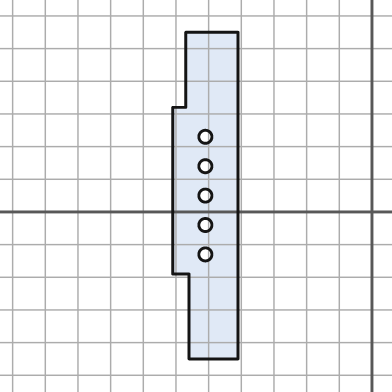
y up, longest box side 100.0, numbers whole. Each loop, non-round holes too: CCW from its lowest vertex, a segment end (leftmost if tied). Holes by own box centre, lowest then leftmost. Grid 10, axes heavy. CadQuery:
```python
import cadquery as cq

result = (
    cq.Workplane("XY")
    .moveTo(-56.0, -45.0)
    .lineTo(-41.0, -45.0)
    .lineTo(-41.0, 55.0)
    .lineTo(-57.0, 55.0)
    .lineTo(-57.0, 32.0)
    .lineTo(-61.0, 32.0)
    .lineTo(-61.0, -19.0)
    .lineTo(-56.0, -19.0)
    .close()
    .moveTo(-51.0, -13.0)
    .circle(2.0)
    .moveTo(-51.0, -4.0)
    .circle(2.0)
    .moveTo(-51.0, 5.0)
    .circle(2.0)
    .moveTo(-51.0, 14.0)
    .circle(2.0)
    .moveTo(-51.0, 23.0)
    .circle(2.0)
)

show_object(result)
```